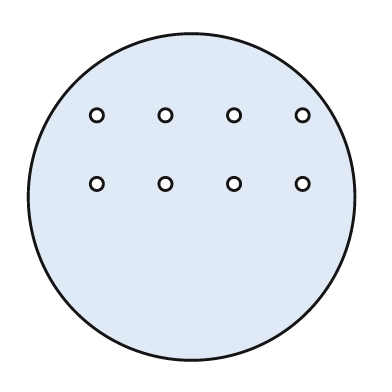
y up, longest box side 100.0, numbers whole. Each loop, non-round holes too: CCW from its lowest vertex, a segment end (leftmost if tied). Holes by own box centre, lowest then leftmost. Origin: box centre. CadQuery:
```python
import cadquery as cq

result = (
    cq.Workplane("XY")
    .moveTo(0.0, 0.0)
    .circle(50.0)
    .moveTo(-29.0, 4.0)
    .circle(2.0)
    .moveTo(-8.0, 4.0)
    .circle(2.0)
    .moveTo(13.0, 4.0)
    .circle(2.0)
    .moveTo(34.0, 4.0)
    .circle(2.0)
    .moveTo(-29.0, 25.0)
    .circle(2.0)
    .moveTo(-8.0, 25.0)
    .circle(2.0)
    .moveTo(13.0, 25.0)
    .circle(2.0)
    .moveTo(34.0, 25.0)
    .circle(2.0)
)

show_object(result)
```